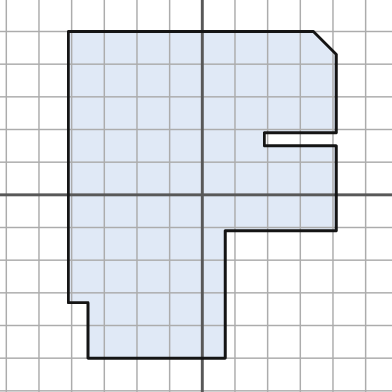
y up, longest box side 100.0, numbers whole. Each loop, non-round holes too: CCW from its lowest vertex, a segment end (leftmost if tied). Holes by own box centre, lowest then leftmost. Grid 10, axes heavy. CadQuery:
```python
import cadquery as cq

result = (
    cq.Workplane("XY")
    .moveTo(-35.0, -50.0)
    .lineTo(7.0, -50.0)
    .lineTo(7.0, -11.0)
    .lineTo(41.0, -11.0)
    .lineTo(41.0, 15.0)
    .lineTo(19.0, 15.0)
    .lineTo(19.0, 19.0)
    .lineTo(41.0, 19.0)
    .lineTo(41.0, 43.0)
    .lineTo(34.0, 50.0)
    .lineTo(-41.0, 50.0)
    .lineTo(-41.0, -33.0)
    .lineTo(-35.0, -33.0)
    .close()
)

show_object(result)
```